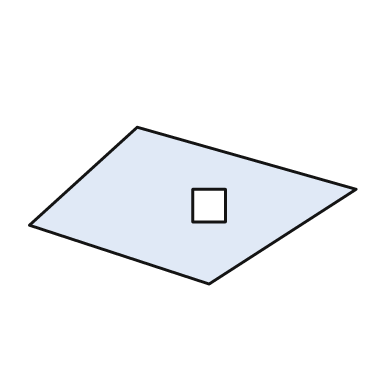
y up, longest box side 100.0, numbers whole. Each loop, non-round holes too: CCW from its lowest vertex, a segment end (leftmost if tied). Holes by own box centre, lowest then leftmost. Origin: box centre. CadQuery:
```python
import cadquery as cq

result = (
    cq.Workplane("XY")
    .moveTo(5.0, -24.0)
    .lineTo(50.0, 5.0)
    .lineTo(-17.0, 24.0)
    .lineTo(-50.0, -6.0)
    .close()
    .moveTo(0.0, -5.0)
    .lineTo(10.0, -5.0)
    .lineTo(10.0, 5.0)
    .lineTo(0.0, 5.0)
    .close()
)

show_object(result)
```